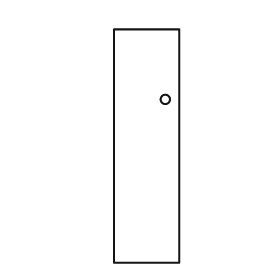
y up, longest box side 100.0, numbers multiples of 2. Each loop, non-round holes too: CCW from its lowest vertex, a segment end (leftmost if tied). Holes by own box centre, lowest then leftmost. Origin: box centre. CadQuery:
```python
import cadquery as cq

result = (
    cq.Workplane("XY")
    .moveTo(-14.0, -50.0)
    .lineTo(14.0, -50.0)
    .lineTo(14.0, 50.0)
    .lineTo(-14.0, 50.0)
    .close()
    .moveTo(8.0, 20.0)
    .circle(2.0)
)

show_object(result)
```